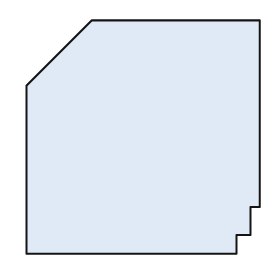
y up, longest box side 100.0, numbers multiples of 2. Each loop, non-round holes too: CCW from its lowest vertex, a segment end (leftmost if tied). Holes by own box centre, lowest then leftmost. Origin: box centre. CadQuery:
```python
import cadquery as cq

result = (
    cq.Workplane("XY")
    .moveTo(-50.0, -50.0)
    .lineTo(40.0, -50.0)
    .lineTo(40.0, -42.0)
    .lineTo(46.0, -42.0)
    .lineTo(46.0, -30.0)
    .lineTo(50.0, -30.0)
    .lineTo(50.0, 50.0)
    .lineTo(-22.0, 50.0)
    .lineTo(-50.0, 22.0)
    .close()
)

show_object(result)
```